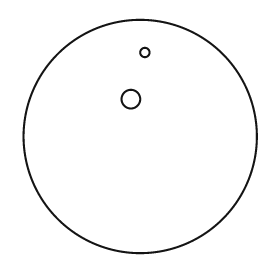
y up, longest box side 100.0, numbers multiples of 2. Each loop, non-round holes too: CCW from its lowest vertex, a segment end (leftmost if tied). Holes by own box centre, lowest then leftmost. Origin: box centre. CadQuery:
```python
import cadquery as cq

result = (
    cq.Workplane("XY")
    .moveTo(0.0, 0.0)
    .circle(50.0)
    .moveTo(-4.0, 16.0)
    .circle(4.0)
    .moveTo(2.0, 36.0)
    .circle(2.0)
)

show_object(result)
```